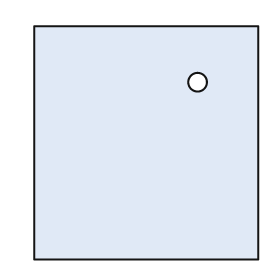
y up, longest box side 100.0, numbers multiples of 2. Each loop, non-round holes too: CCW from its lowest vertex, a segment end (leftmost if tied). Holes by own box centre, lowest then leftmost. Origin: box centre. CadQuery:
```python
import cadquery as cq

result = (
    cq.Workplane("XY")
    .moveTo(-48.0, -50.0)
    .lineTo(48.0, -50.0)
    .lineTo(48.0, 50.0)
    .lineTo(-48.0, 50.0)
    .close()
    .moveTo(22.0, 26.0)
    .circle(4.0)
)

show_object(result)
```